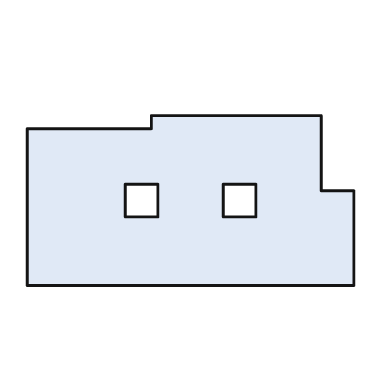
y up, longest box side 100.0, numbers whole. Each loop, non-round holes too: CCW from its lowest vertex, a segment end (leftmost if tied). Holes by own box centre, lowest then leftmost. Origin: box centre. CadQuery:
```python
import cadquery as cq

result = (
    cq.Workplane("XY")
    .moveTo(-50.0, -26.0)
    .lineTo(50.0, -26.0)
    .lineTo(50.0, 3.0)
    .lineTo(40.0, 3.0)
    .lineTo(40.0, 26.0)
    .lineTo(-12.0, 26.0)
    .lineTo(-12.0, 22.0)
    .lineTo(-50.0, 22.0)
    .close()
    .moveTo(-20.0, -5.0)
    .lineTo(-10.0, -5.0)
    .lineTo(-10.0, 5.0)
    .lineTo(-20.0, 5.0)
    .close()
    .moveTo(10.0, -5.0)
    .lineTo(20.0, -5.0)
    .lineTo(20.0, 5.0)
    .lineTo(10.0, 5.0)
    .close()
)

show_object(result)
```